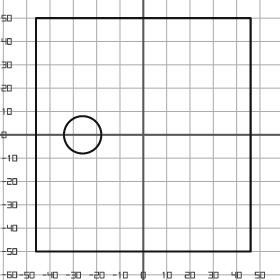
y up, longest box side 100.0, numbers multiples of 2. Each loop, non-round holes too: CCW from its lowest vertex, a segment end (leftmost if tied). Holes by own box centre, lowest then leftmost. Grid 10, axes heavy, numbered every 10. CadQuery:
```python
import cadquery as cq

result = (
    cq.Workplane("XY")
    .moveTo(-46.0, -50.0)
    .lineTo(46.0, -50.0)
    .lineTo(46.0, 50.0)
    .lineTo(-46.0, 50.0)
    .close()
    .moveTo(-26.0, 0.0)
    .circle(8.0)
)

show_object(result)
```